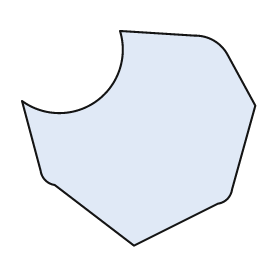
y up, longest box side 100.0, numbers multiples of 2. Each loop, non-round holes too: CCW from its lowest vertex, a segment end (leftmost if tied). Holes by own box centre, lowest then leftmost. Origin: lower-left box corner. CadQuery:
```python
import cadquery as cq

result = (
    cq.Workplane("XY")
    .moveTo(48.0, 0.0)
    .lineTo(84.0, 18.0)
    .threePointArc((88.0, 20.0), (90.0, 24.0))
    .lineTo(100.0, 60.0)
    .lineTo(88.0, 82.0)
    .threePointArc((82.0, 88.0), (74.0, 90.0))
    .lineTo(42.0, 92.0)
    .threePointArc((32.0, 62.0), (0.0, 62.0))
    .lineTo(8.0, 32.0)
    .threePointArc((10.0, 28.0), (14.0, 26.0))
    .close()
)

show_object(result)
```